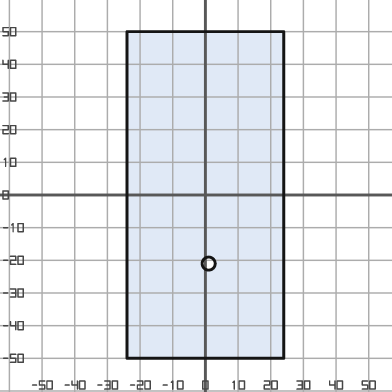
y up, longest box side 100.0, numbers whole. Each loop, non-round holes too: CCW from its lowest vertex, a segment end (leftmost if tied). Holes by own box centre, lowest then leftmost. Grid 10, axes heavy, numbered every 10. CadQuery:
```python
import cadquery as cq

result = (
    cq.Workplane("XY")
    .moveTo(-24.0, -50.0)
    .lineTo(24.0, -50.0)
    .lineTo(24.0, 50.0)
    .lineTo(-24.0, 50.0)
    .close()
    .moveTo(1.0, -21.0)
    .circle(2.0)
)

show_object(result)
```